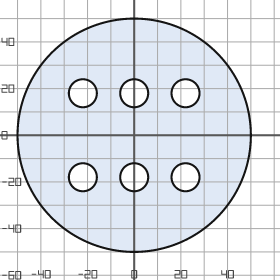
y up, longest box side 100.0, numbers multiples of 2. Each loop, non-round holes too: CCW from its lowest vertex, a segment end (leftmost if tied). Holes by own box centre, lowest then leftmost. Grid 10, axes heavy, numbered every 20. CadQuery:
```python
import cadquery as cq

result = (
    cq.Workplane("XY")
    .moveTo(0.0, 0.0)
    .circle(50.0)
    .moveTo(-22.0, -18.0)
    .circle(6.0)
    .moveTo(0.0, -18.0)
    .circle(6.0)
    .moveTo(22.0, -18.0)
    .circle(6.0)
    .moveTo(-22.0, 18.0)
    .circle(6.0)
    .moveTo(0.0, 18.0)
    .circle(6.0)
    .moveTo(22.0, 18.0)
    .circle(6.0)
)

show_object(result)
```